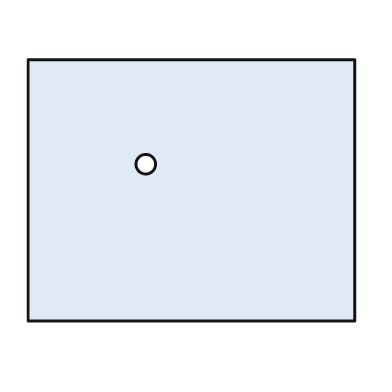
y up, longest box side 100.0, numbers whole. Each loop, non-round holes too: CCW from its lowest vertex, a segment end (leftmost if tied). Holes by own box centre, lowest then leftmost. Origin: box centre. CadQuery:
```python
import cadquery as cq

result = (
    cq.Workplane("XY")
    .moveTo(-50.0, -40.0)
    .lineTo(50.0, -40.0)
    .lineTo(50.0, 40.0)
    .lineTo(-50.0, 40.0)
    .close()
    .moveTo(-14.0, 8.0)
    .circle(3.0)
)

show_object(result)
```